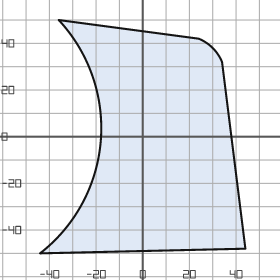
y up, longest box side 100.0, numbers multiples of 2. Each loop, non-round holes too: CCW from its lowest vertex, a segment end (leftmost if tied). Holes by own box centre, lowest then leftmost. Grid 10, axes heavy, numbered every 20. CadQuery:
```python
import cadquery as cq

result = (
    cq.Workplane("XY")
    .moveTo(-44.0, -50.0)
    .lineTo(44.0, -48.0)
    .lineTo(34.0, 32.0)
    .threePointArc((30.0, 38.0), (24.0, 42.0))
    .lineTo(-36.0, 50.0)
    .threePointArc((-18.0, -2.0), (-44.0, -50.0))
    .close()
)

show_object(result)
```